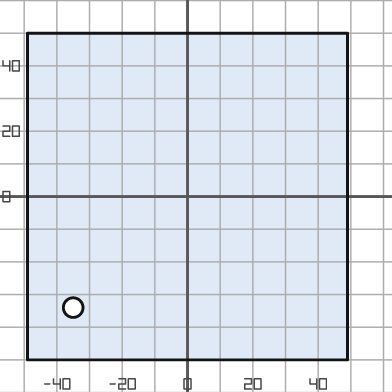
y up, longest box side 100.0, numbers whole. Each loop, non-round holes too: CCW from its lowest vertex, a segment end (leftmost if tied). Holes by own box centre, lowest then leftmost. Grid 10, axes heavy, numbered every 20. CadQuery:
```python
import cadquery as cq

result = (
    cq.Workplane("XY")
    .moveTo(-49.0, -50.0)
    .lineTo(49.0, -50.0)
    .lineTo(49.0, 50.0)
    .lineTo(-49.0, 50.0)
    .close()
    .moveTo(-35.0, -34.0)
    .circle(3.0)
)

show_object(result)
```